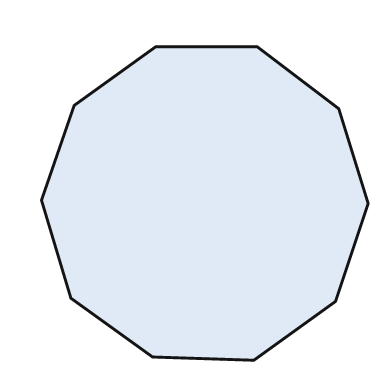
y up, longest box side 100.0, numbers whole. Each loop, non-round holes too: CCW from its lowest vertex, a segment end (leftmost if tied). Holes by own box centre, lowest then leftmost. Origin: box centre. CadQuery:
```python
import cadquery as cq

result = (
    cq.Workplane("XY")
    .moveTo(15.0, -48.0)
    .lineTo(40.0, -30.0)
    .lineTo(50.0, 0.0)
    .lineTo(41.0, 29.0)
    .lineTo(16.0, 48.0)
    .lineTo(-15.0, 48.0)
    .lineTo(-40.0, 30.0)
    .lineTo(-50.0, 1.0)
    .lineTo(-41.0, -29.0)
    .lineTo(-16.0, -47.0)
    .close()
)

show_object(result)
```